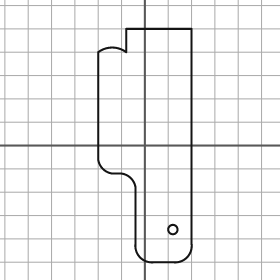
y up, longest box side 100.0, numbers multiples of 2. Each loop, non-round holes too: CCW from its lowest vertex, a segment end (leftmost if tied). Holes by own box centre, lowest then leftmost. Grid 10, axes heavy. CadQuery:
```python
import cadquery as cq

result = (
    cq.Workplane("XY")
    .moveTo(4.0, -50.0)
    .lineTo(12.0, -50.0)
    .threePointArc((18.0, -48.0), (20.0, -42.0))
    .lineTo(20.0, 50.0)
    .lineTo(-8.0, 50.0)
    .lineTo(-8.0, 40.0)
    .threePointArc((-14.0, 42.0), (-20.0, 40.0))
    .lineTo(-20.0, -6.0)
    .threePointArc((-18.0, -10.0), (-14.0, -12.0))
    .lineTo(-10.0, -12.0)
    .threePointArc((-6.0, -14.0), (-4.0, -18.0))
    .lineTo(-4.0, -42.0)
    .threePointArc((-2.0, -48.0), (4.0, -50.0))
    .close()
    .moveTo(12.0, -36.0)
    .circle(2.0)
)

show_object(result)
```